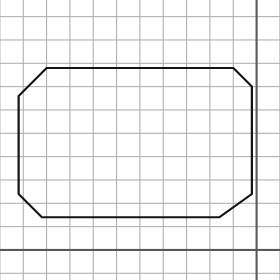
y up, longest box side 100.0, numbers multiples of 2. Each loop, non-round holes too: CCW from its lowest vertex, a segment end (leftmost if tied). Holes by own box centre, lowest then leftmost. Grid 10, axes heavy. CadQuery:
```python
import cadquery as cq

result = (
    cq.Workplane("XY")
    .moveTo(-92.0, 14.0)
    .lineTo(-16.0, 14.0)
    .lineTo(-2.0, 24.0)
    .lineTo(-2.0, 70.0)
    .lineTo(-10.0, 78.0)
    .lineTo(-90.0, 78.0)
    .lineTo(-102.0, 66.0)
    .lineTo(-102.0, 24.0)
    .close()
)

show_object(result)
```